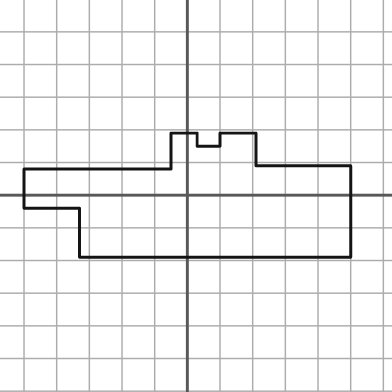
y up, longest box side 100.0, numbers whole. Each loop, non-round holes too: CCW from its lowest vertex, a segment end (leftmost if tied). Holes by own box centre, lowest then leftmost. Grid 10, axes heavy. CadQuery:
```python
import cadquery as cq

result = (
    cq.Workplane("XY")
    .moveTo(-33.0, -19.0)
    .lineTo(50.0, -19.0)
    .lineTo(50.0, 9.0)
    .lineTo(21.0, 9.0)
    .lineTo(21.0, 19.0)
    .lineTo(10.0, 19.0)
    .lineTo(10.0, 15.0)
    .lineTo(3.0, 15.0)
    .lineTo(3.0, 19.0)
    .lineTo(-5.0, 19.0)
    .lineTo(-5.0, 8.0)
    .lineTo(-50.0, 8.0)
    .lineTo(-50.0, -4.0)
    .lineTo(-33.0, -4.0)
    .close()
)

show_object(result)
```